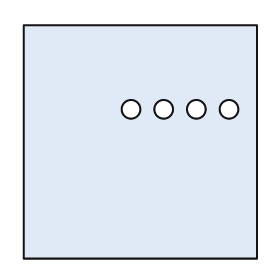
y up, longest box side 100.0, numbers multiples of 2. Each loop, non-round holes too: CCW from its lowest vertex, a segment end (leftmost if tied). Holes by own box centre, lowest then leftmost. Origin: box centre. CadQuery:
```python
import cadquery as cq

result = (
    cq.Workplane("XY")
    .moveTo(-50.0, -50.0)
    .lineTo(50.0, -50.0)
    .lineTo(50.0, 50.0)
    .lineTo(-50.0, 50.0)
    .close()
    .moveTo(-4.0, 14.0)
    .circle(4.0)
    .moveTo(10.0, 14.0)
    .circle(4.0)
    .moveTo(24.0, 14.0)
    .circle(4.0)
    .moveTo(38.0, 14.0)
    .circle(4.0)
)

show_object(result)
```